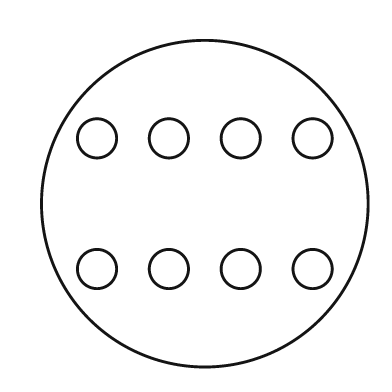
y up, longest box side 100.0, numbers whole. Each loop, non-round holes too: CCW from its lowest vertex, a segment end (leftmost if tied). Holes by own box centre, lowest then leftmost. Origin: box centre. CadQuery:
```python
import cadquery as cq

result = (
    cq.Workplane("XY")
    .moveTo(0.0, 0.0)
    .circle(50.0)
    .moveTo(-33.0, -20.0)
    .circle(6.0)
    .moveTo(-11.0, -20.0)
    .circle(6.0)
    .moveTo(11.0, -20.0)
    .circle(6.0)
    .moveTo(33.0, -20.0)
    .circle(6.0)
    .moveTo(-33.0, 20.0)
    .circle(6.0)
    .moveTo(-11.0, 20.0)
    .circle(6.0)
    .moveTo(11.0, 20.0)
    .circle(6.0)
    .moveTo(33.0, 20.0)
    .circle(6.0)
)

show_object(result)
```